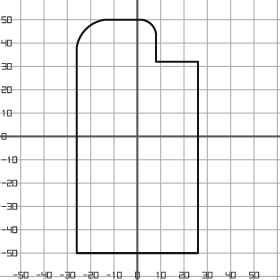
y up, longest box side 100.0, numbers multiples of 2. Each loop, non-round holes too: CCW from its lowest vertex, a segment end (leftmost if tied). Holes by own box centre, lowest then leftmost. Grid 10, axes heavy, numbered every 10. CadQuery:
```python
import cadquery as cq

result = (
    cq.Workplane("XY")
    .moveTo(-26.0, -50.0)
    .lineTo(26.0, -50.0)
    .lineTo(26.0, 32.0)
    .lineTo(8.0, 32.0)
    .lineTo(8.0, 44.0)
    .threePointArc((6.0, 48.0), (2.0, 50.0))
    .lineTo(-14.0, 50.0)
    .threePointArc((-22.0, 46.0), (-26.0, 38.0))
    .close()
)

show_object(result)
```